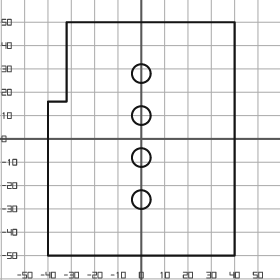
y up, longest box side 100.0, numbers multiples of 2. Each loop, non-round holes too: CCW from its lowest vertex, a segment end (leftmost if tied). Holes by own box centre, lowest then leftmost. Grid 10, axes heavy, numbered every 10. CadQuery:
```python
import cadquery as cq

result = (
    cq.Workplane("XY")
    .moveTo(-40.0, -50.0)
    .lineTo(40.0, -50.0)
    .lineTo(40.0, 50.0)
    .lineTo(-32.0, 50.0)
    .lineTo(-32.0, 16.0)
    .lineTo(-40.0, 16.0)
    .close()
    .moveTo(0.0, -26.0)
    .circle(4.0)
    .moveTo(0.0, -8.0)
    .circle(4.0)
    .moveTo(0.0, 10.0)
    .circle(4.0)
    .moveTo(0.0, 28.0)
    .circle(4.0)
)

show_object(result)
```